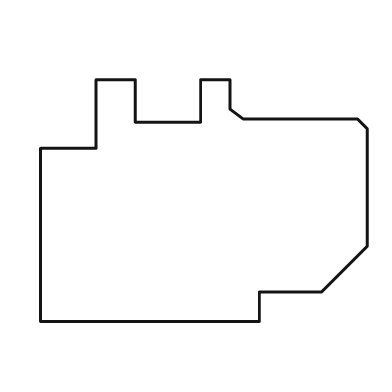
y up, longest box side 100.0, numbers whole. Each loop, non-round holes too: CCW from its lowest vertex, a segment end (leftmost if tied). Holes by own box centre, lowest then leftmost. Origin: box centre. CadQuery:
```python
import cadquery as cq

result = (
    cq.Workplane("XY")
    .moveTo(-50.0, -37.0)
    .lineTo(17.0, -37.0)
    .lineTo(17.0, -28.0)
    .lineTo(36.0, -28.0)
    .lineTo(50.0, -14.0)
    .lineTo(50.0, 22.0)
    .lineTo(47.0, 25.0)
    .lineTo(12.0, 25.0)
    .lineTo(8.0, 28.0)
    .lineTo(8.0, 37.0)
    .lineTo(-1.0, 37.0)
    .lineTo(-1.0, 24.0)
    .lineTo(-21.0, 24.0)
    .lineTo(-21.0, 37.0)
    .lineTo(-33.0, 37.0)
    .lineTo(-33.0, 16.0)
    .lineTo(-50.0, 16.0)
    .close()
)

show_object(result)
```